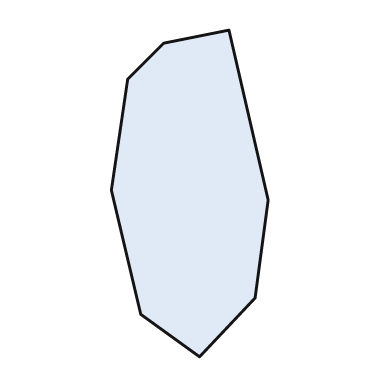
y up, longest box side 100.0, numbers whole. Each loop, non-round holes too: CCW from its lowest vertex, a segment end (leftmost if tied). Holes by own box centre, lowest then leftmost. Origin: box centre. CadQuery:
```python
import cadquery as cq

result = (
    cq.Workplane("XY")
    .moveTo(3.0, -50.0)
    .lineTo(20.0, -32.0)
    .lineTo(24.0, -2.0)
    .lineTo(12.0, 50.0)
    .lineTo(-8.0, 46.0)
    .lineTo(-19.0, 35.0)
    .lineTo(-24.0, 1.0)
    .lineTo(-15.0, -37.0)
    .close()
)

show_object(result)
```